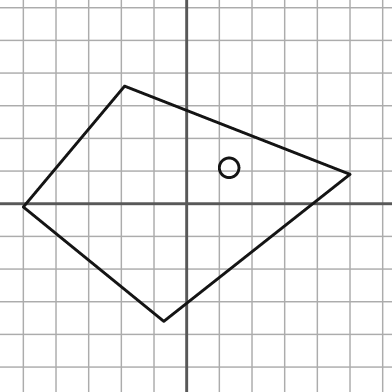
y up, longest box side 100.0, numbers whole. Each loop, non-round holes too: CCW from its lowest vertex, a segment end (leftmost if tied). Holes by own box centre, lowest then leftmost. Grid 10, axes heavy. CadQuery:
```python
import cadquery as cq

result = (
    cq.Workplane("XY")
    .moveTo(-7.0, -36.0)
    .lineTo(50.0, 9.0)
    .lineTo(-19.0, 36.0)
    .lineTo(-50.0, -1.0)
    .close()
    .moveTo(13.0, 11.0)
    .circle(3.0)
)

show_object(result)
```